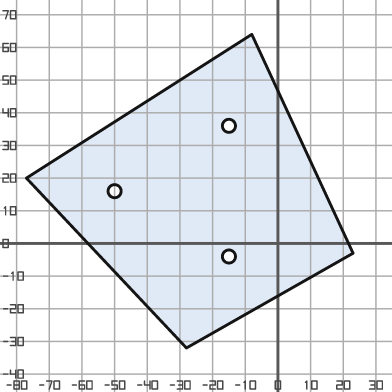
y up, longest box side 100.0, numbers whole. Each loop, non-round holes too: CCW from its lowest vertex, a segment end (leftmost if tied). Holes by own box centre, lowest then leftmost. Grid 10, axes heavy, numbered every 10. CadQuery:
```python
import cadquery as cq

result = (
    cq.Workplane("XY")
    .moveTo(-28.0, -32.0)
    .lineTo(23.0, -3.0)
    .lineTo(-8.0, 64.0)
    .lineTo(-77.0, 20.0)
    .close()
    .moveTo(-15.0, -4.0)
    .circle(2.0)
    .moveTo(-50.0, 16.0)
    .circle(2.0)
    .moveTo(-15.0, 36.0)
    .circle(2.0)
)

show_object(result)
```